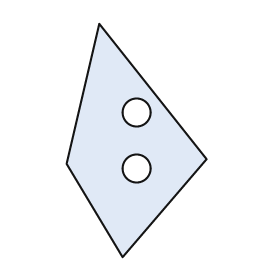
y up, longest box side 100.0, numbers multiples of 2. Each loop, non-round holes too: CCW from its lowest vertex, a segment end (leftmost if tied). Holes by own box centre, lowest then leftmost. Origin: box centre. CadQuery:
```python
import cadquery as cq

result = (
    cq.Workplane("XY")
    .moveTo(-6.0, -50.0)
    .lineTo(30.0, -8.0)
    .lineTo(-16.0, 50.0)
    .lineTo(-30.0, -10.0)
    .close()
    .moveTo(0.0, -12.0)
    .circle(6.0)
    .moveTo(0.0, 12.0)
    .circle(6.0)
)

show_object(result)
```